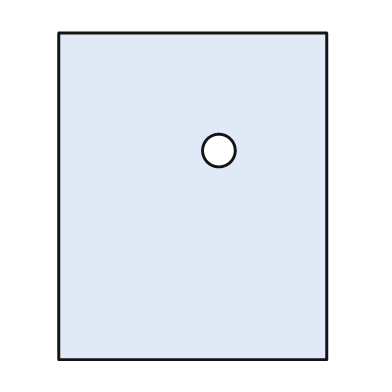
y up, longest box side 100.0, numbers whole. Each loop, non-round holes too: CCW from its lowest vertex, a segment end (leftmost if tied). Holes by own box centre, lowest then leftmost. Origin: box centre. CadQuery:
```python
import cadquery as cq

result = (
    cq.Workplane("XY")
    .moveTo(-41.0, -50.0)
    .lineTo(41.0, -50.0)
    .lineTo(41.0, 50.0)
    .lineTo(-41.0, 50.0)
    .close()
    .moveTo(8.0, 14.0)
    .circle(5.0)
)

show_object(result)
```